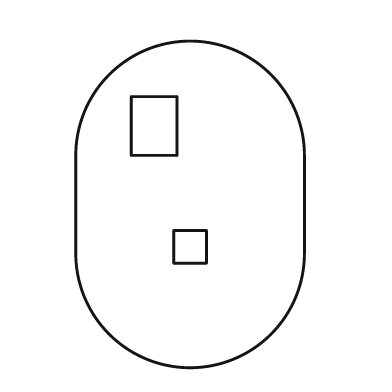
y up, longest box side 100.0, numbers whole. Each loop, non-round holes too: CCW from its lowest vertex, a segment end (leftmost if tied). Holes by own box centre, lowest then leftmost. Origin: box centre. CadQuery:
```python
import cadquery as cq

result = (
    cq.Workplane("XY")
    .moveTo(-35.0, -15.0)
    .threePointArc((0.0, -50.0), (35.0, -15.0))
    .lineTo(35.0, 15.0)
    .threePointArc((0.0, 50.0), (-35.0, 15.0))
    .close()
    .moveTo(-5.0, -18.0)
    .lineTo(5.0, -18.0)
    .lineTo(5.0, -8.0)
    .lineTo(-5.0, -8.0)
    .close()
    .moveTo(-18.0, 15.0)
    .lineTo(-4.0, 15.0)
    .lineTo(-4.0, 33.0)
    .lineTo(-18.0, 33.0)
    .close()
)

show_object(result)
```